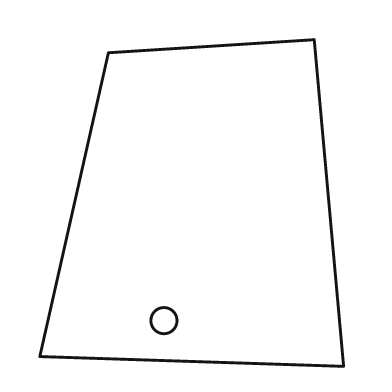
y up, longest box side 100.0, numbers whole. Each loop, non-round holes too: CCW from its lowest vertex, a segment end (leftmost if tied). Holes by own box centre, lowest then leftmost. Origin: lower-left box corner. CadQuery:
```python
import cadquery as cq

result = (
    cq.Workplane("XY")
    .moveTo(93.0, 0.0)
    .lineTo(84.0, 100.0)
    .lineTo(21.0, 96.0)
    .lineTo(0.0, 3.0)
    .close()
    .moveTo(38.0, 14.0)
    .circle(4.0)
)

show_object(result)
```